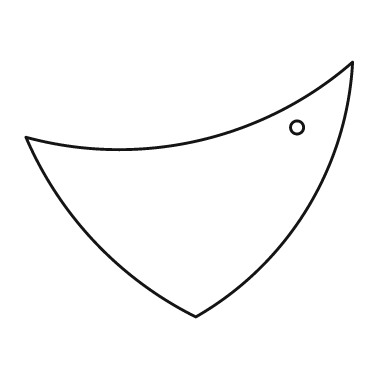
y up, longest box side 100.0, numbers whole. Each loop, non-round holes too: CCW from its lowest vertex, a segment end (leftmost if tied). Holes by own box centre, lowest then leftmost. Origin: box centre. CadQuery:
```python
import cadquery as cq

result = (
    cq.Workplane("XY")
    .moveTo(2.0, -39.0)
    .threePointArc((36.0, -6.0), (50.0, 39.0))
    .threePointArc((3.0, 15.0), (-50.0, 16.0))
    .threePointArc((-29.0, -16.0), (2.0, -39.0))
    .close()
    .moveTo(33.0, 19.0)
    .circle(2.0)
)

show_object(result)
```